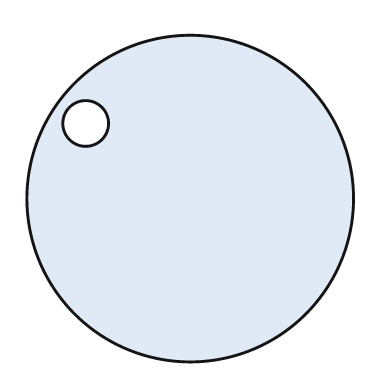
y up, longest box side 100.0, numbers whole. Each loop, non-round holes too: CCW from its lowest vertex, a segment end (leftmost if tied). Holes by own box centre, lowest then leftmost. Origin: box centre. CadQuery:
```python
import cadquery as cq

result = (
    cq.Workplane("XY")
    .moveTo(0.0, 0.0)
    .circle(50.0)
    .moveTo(-32.0, 23.0)
    .circle(7.0)
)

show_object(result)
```